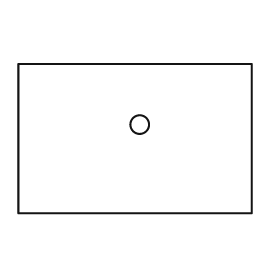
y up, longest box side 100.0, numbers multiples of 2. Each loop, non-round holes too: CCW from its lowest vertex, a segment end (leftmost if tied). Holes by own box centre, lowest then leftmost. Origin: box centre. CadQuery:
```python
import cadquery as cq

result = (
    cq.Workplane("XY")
    .moveTo(-50.0, -32.0)
    .lineTo(50.0, -32.0)
    .lineTo(50.0, 32.0)
    .lineTo(-50.0, 32.0)
    .close()
    .moveTo(2.0, 6.0)
    .circle(4.0)
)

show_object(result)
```